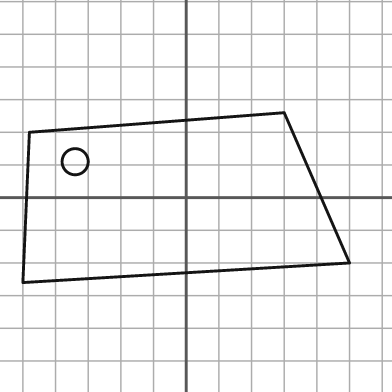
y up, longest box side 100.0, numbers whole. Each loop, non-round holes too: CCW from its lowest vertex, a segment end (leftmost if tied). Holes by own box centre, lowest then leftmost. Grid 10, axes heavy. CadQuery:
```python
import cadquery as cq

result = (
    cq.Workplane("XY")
    .moveTo(-50.0, -26.0)
    .lineTo(50.0, -20.0)
    .lineTo(30.0, 26.0)
    .lineTo(-48.0, 20.0)
    .close()
    .moveTo(-34.0, 11.0)
    .circle(4.0)
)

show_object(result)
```